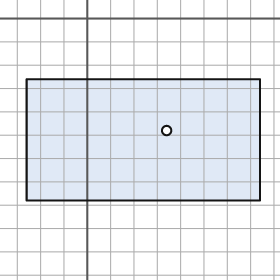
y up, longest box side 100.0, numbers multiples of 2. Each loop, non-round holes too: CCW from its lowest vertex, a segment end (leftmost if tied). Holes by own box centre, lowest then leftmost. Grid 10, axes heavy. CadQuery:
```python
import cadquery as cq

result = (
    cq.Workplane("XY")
    .moveTo(-26.0, -78.0)
    .lineTo(74.0, -78.0)
    .lineTo(74.0, -26.0)
    .lineTo(-26.0, -26.0)
    .close()
    .moveTo(34.0, -48.0)
    .circle(2.0)
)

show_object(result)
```